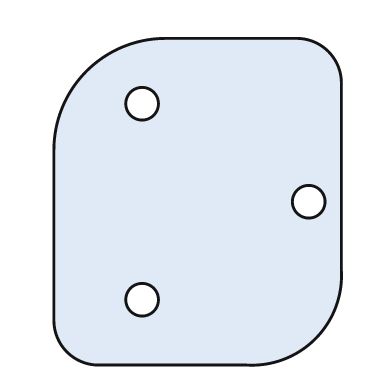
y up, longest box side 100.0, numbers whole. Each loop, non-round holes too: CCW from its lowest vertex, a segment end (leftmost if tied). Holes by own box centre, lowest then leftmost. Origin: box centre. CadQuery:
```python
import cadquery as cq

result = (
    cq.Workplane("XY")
    .moveTo(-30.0, -50.0)
    .lineTo(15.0, -50.0)
    .threePointArc((36.0, -42.0), (44.0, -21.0))
    .lineTo(44.0, 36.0)
    .threePointArc((40.0, 46.0), (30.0, 50.0))
    .lineTo(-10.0, 50.0)
    .threePointArc((-34.0, 40.0), (-44.0, 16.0))
    .lineTo(-44.0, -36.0)
    .threePointArc((-40.0, -46.0), (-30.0, -50.0))
    .close()
    .moveTo(-17.0, -30.0)
    .circle(5.0)
    .moveTo(34.0, 0.0)
    .circle(5.0)
    .moveTo(-17.0, 30.0)
    .circle(5.0)
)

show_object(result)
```